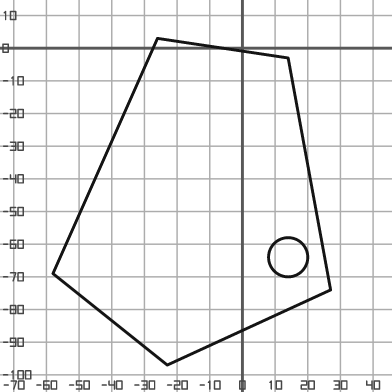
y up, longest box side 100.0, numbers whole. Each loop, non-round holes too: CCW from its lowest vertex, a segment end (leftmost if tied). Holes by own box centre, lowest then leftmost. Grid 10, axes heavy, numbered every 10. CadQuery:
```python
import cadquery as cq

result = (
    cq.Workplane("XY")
    .moveTo(-23.0, -97.0)
    .lineTo(27.0, -74.0)
    .lineTo(14.0, -3.0)
    .lineTo(-26.0, 3.0)
    .lineTo(-58.0, -69.0)
    .close()
    .moveTo(14.0, -64.0)
    .circle(6.0)
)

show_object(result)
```